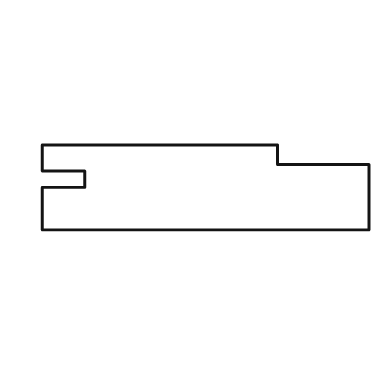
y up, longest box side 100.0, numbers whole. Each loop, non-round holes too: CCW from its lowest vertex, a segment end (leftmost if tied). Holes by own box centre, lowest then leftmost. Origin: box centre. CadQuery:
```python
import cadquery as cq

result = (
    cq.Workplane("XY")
    .moveTo(-50.0, -13.0)
    .lineTo(50.0, -13.0)
    .lineTo(50.0, 7.0)
    .lineTo(22.0, 7.0)
    .lineTo(22.0, 13.0)
    .lineTo(-50.0, 13.0)
    .lineTo(-50.0, 5.0)
    .lineTo(-37.0, 5.0)
    .lineTo(-37.0, 0.0)
    .lineTo(-50.0, 0.0)
    .close()
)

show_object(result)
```